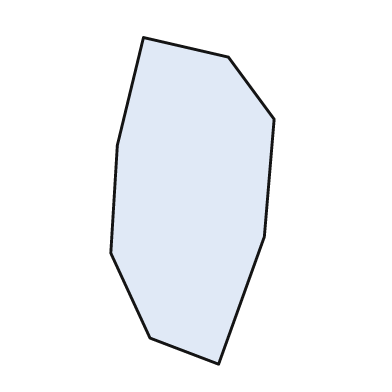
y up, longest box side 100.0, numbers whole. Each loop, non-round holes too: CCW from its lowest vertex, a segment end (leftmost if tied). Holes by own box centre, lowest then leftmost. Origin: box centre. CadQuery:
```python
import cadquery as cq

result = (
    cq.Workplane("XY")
    .moveTo(8.0, -50.0)
    .lineTo(22.0, -11.0)
    .lineTo(25.0, 25.0)
    .lineTo(11.0, 44.0)
    .lineTo(-15.0, 50.0)
    .lineTo(-23.0, 17.0)
    .lineTo(-25.0, -16.0)
    .lineTo(-13.0, -42.0)
    .close()
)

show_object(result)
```